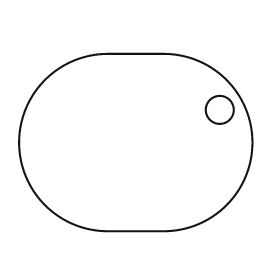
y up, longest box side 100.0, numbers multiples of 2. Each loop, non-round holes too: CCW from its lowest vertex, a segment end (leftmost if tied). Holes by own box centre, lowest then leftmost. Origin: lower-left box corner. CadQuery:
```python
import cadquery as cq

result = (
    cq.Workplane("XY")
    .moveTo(38.0, 0.0)
    .lineTo(62.0, 0.0)
    .threePointArc((100.0, 38.0), (62.0, 76.0))
    .lineTo(38.0, 76.0)
    .threePointArc((0.0, 38.0), (38.0, 0.0))
    .close()
    .moveTo(86.0, 52.0)
    .circle(6.0)
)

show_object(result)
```